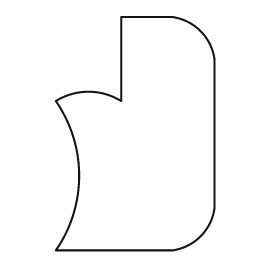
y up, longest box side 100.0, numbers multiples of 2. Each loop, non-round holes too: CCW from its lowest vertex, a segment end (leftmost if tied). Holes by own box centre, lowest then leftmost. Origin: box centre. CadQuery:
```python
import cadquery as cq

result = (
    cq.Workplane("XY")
    .moveTo(-34.0, -50.0)
    .lineTo(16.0, -50.0)
    .threePointArc((28.0, -44.0), (34.0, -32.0))
    .lineTo(34.0, 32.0)
    .threePointArc((28.0, 44.0), (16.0, 50.0))
    .lineTo(-6.0, 50.0)
    .lineTo(-6.0, 14.0)
    .threePointArc((-20.0, 18.0), (-34.0, 14.0))
    .threePointArc((-24.0, -18.0), (-34.0, -50.0))
    .close()
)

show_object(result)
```